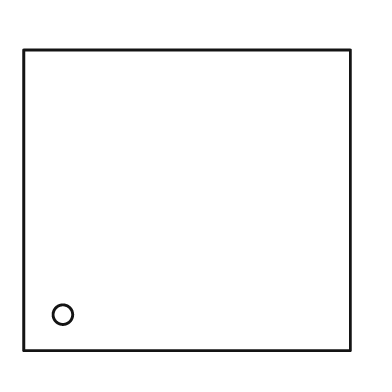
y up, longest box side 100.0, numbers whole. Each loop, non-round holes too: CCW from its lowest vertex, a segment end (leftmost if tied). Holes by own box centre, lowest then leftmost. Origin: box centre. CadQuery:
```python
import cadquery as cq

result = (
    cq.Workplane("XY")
    .moveTo(-50.0, -46.0)
    .lineTo(50.0, -46.0)
    .lineTo(50.0, 46.0)
    .lineTo(-50.0, 46.0)
    .close()
    .moveTo(-38.0, -35.0)
    .circle(3.0)
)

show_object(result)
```